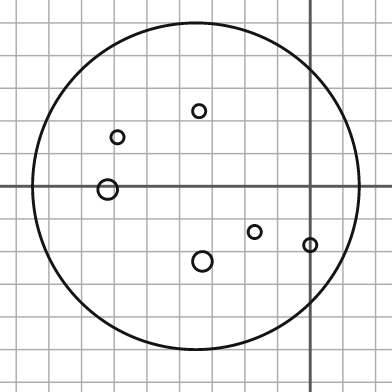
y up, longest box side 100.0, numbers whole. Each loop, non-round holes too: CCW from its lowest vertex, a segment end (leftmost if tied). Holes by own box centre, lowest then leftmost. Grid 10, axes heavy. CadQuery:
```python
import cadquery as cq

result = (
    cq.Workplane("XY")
    .moveTo(-35.0, 0.0)
    .circle(50.0)
    .moveTo(-33.0, -23.0)
    .circle(3.0)
    .moveTo(0.0, -18.0)
    .circle(2.0)
    .moveTo(-17.0, -14.0)
    .circle(2.0)
    .moveTo(-62.0, -1.0)
    .circle(3.0)
    .moveTo(-59.0, 15.0)
    .circle(2.0)
    .moveTo(-34.0, 23.0)
    .circle(2.0)
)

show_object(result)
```